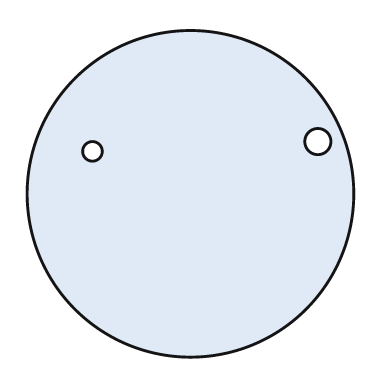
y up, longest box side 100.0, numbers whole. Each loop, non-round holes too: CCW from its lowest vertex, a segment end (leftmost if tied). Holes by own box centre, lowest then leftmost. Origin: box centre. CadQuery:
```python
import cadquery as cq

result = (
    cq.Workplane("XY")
    .moveTo(0.0, 0.0)
    .circle(50.0)
    .moveTo(-30.0, 13.0)
    .circle(3.0)
    .moveTo(39.0, 16.0)
    .circle(4.0)
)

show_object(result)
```